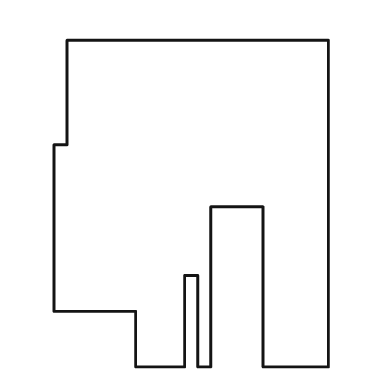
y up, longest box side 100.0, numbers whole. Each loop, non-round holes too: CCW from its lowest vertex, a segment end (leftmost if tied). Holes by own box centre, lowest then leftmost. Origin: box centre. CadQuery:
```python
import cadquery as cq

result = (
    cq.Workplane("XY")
    .moveTo(-17.0, -50.0)
    .lineTo(-2.0, -50.0)
    .lineTo(-2.0, -22.0)
    .lineTo(2.0, -22.0)
    .lineTo(2.0, -50.0)
    .lineTo(6.0, -50.0)
    .lineTo(6.0, -1.0)
    .lineTo(22.0, -1.0)
    .lineTo(22.0, -50.0)
    .lineTo(42.0, -50.0)
    .lineTo(42.0, 50.0)
    .lineTo(-38.0, 50.0)
    .lineTo(-38.0, 18.0)
    .lineTo(-42.0, 18.0)
    .lineTo(-42.0, -33.0)
    .lineTo(-17.0, -33.0)
    .close()
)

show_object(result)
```